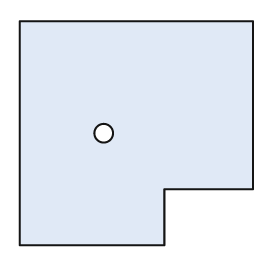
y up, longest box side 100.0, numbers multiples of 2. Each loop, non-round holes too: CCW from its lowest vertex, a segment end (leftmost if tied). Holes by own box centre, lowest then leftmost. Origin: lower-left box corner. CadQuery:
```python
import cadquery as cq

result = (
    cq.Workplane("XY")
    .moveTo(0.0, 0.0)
    .lineTo(62.0, 0.0)
    .lineTo(62.0, 24.0)
    .lineTo(100.0, 24.0)
    .lineTo(100.0, 96.0)
    .lineTo(0.0, 96.0)
    .close()
    .moveTo(36.0, 48.0)
    .circle(4.0)
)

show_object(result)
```